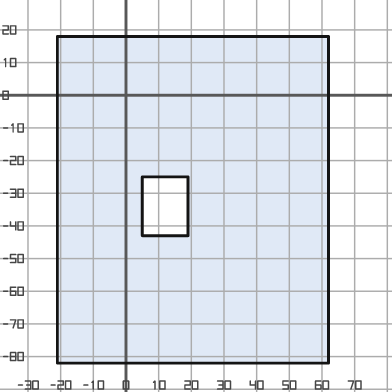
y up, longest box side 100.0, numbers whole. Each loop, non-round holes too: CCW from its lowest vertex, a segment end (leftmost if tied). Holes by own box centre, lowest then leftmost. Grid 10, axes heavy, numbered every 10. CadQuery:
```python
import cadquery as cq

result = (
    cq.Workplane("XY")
    .moveTo(-21.0, -82.0)
    .lineTo(62.0, -82.0)
    .lineTo(62.0, 18.0)
    .lineTo(-21.0, 18.0)
    .close()
    .moveTo(5.0, -43.0)
    .lineTo(19.0, -43.0)
    .lineTo(19.0, -25.0)
    .lineTo(5.0, -25.0)
    .close()
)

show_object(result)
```